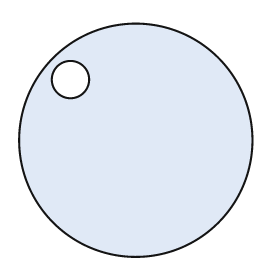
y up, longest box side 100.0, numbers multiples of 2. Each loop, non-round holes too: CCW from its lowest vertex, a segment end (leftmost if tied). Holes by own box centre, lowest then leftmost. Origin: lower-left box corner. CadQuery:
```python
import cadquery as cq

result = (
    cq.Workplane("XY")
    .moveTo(50.0, 50.0)
    .circle(50.0)
    .moveTo(22.0, 76.0)
    .circle(8.0)
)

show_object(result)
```